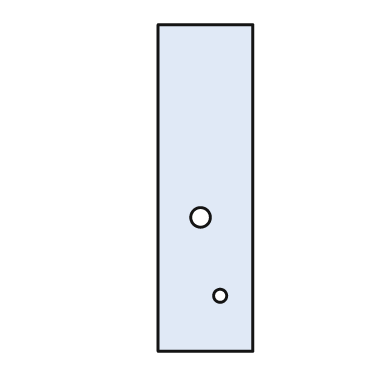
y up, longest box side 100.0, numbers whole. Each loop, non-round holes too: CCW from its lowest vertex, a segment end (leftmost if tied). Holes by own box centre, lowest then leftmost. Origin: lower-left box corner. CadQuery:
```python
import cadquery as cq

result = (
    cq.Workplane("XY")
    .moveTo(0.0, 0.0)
    .lineTo(29.0, 0.0)
    .lineTo(29.0, 100.0)
    .lineTo(0.0, 100.0)
    .close()
    .moveTo(19.0, 17.0)
    .circle(2.0)
    .moveTo(13.0, 41.0)
    .circle(3.0)
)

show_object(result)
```